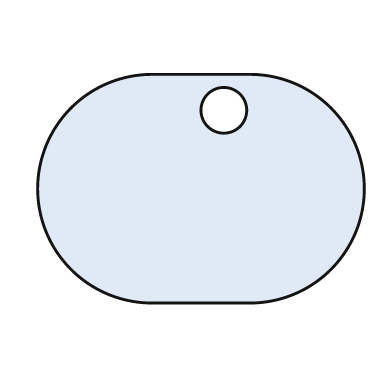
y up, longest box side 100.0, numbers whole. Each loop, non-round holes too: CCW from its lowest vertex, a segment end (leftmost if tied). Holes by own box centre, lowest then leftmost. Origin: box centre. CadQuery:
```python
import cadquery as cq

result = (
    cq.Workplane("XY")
    .moveTo(-15.0, -35.0)
    .lineTo(15.0, -35.0)
    .threePointArc((50.0, 0.0), (15.0, 35.0))
    .lineTo(-15.0, 35.0)
    .threePointArc((-50.0, 0.0), (-15.0, -35.0))
    .close()
    .moveTo(7.0, 24.0)
    .circle(7.0)
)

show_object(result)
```